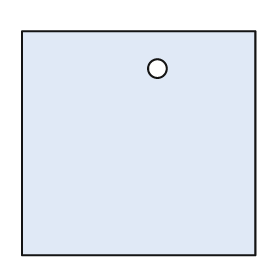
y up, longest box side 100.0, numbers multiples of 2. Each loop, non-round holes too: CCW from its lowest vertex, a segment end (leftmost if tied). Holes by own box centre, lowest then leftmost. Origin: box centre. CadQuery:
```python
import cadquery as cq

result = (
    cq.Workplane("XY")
    .moveTo(-50.0, -48.0)
    .lineTo(50.0, -48.0)
    .lineTo(50.0, 48.0)
    .lineTo(-50.0, 48.0)
    .close()
    .moveTo(8.0, 32.0)
    .circle(4.0)
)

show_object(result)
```